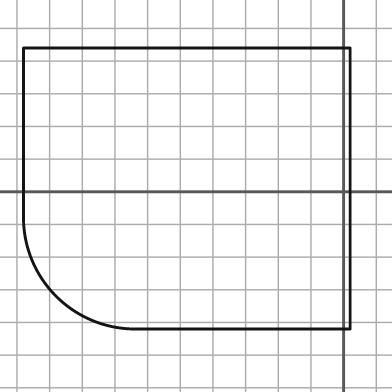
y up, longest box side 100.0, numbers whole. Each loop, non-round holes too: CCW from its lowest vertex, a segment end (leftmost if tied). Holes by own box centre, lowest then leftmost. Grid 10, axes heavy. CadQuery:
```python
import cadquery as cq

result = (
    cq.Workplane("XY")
    .moveTo(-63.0, -42.0)
    .lineTo(2.0, -42.0)
    .lineTo(2.0, 44.0)
    .lineTo(-98.0, 44.0)
    .lineTo(-98.0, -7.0)
    .threePointArc((-88.0, -32.0), (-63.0, -42.0))
    .close()
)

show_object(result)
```